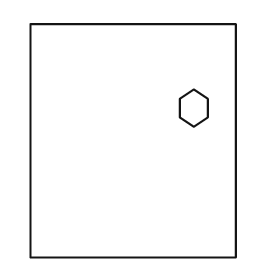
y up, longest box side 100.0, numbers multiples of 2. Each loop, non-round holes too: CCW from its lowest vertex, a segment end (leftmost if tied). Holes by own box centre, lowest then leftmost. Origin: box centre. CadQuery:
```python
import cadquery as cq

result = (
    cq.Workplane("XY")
    .moveTo(-44.0, -50.0)
    .lineTo(44.0, -50.0)
    .lineTo(44.0, 50.0)
    .lineTo(-44.0, 50.0)
    .close()
    .moveTo(26.0, 6.0)
    .lineTo(32.0, 10.0)
    .lineTo(32.0, 18.0)
    .lineTo(26.0, 22.0)
    .lineTo(20.0, 18.0)
    .lineTo(20.0, 10.0)
    .close()
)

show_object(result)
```